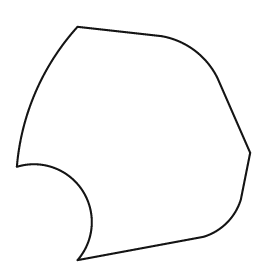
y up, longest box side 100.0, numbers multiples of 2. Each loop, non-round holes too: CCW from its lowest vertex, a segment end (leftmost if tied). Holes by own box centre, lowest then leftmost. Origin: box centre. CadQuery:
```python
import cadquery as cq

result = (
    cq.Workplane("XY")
    .moveTo(-24.0, -50.0)
    .lineTo(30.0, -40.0)
    .threePointArc((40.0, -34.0), (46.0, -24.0))
    .lineTo(50.0, -4.0)
    .lineTo(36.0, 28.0)
    .threePointArc((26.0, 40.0), (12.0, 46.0))
    .lineTo(-24.0, 50.0)
    .threePointArc((-42.0, 22.0), (-50.0, -10.0))
    .threePointArc((-22.0, -20.0), (-24.0, -50.0))
    .close()
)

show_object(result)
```